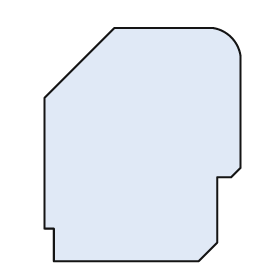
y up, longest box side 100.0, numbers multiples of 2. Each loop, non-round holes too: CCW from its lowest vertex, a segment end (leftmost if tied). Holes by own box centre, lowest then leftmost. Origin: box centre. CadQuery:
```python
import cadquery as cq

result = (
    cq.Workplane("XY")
    .moveTo(-38.0, -50.0)
    .lineTo(24.0, -50.0)
    .lineTo(32.0, -42.0)
    .lineTo(32.0, -14.0)
    .lineTo(38.0, -14.0)
    .lineTo(42.0, -10.0)
    .lineTo(42.0, 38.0)
    .threePointArc((38.0, 46.0), (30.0, 50.0))
    .lineTo(-12.0, 50.0)
    .lineTo(-42.0, 20.0)
    .lineTo(-42.0, -36.0)
    .lineTo(-38.0, -36.0)
    .close()
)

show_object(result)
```